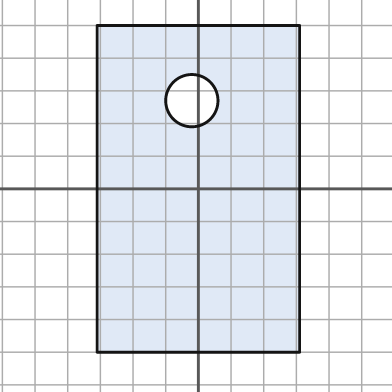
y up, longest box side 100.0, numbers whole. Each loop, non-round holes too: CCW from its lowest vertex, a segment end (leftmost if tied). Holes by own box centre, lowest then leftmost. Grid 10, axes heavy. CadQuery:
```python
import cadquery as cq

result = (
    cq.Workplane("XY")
    .moveTo(-31.0, -50.0)
    .lineTo(31.0, -50.0)
    .lineTo(31.0, 50.0)
    .lineTo(-31.0, 50.0)
    .close()
    .moveTo(-2.0, 27.0)
    .circle(8.0)
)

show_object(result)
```